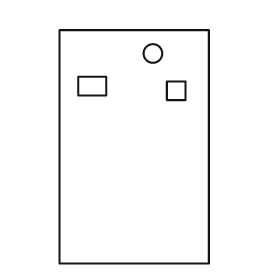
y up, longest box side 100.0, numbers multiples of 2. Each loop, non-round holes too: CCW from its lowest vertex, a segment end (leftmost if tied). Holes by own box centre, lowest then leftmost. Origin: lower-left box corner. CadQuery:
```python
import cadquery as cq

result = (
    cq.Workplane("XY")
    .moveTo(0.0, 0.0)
    .lineTo(64.0, 0.0)
    .lineTo(64.0, 100.0)
    .lineTo(0.0, 100.0)
    .close()
    .moveTo(46.0, 70.0)
    .lineTo(54.0, 70.0)
    .lineTo(54.0, 78.0)
    .lineTo(46.0, 78.0)
    .close()
    .moveTo(8.0, 72.0)
    .lineTo(20.0, 72.0)
    .lineTo(20.0, 80.0)
    .lineTo(8.0, 80.0)
    .close()
    .moveTo(40.0, 90.0)
    .circle(4.0)
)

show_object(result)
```